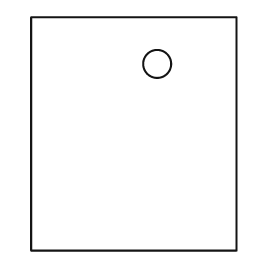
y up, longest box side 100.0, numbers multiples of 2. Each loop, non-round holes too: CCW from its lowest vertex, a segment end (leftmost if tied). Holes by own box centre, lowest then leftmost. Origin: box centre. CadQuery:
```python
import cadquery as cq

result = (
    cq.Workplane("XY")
    .moveTo(-44.0, -50.0)
    .lineTo(44.0, -50.0)
    .lineTo(44.0, 50.0)
    .lineTo(-44.0, 50.0)
    .close()
    .moveTo(10.0, 30.0)
    .circle(6.0)
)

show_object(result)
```